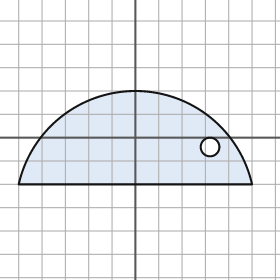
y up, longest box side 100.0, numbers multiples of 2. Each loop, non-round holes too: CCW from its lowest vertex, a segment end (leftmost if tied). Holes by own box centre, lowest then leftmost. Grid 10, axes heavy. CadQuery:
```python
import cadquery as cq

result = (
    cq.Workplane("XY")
    .moveTo(-50.0, -20.0)
    .lineTo(50.0, -20.0)
    .threePointArc((0.0, 20.0), (-50.0, -20.0))
    .close()
    .moveTo(32.0, -4.0)
    .circle(4.0)
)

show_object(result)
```